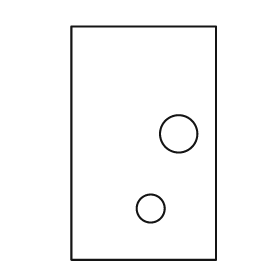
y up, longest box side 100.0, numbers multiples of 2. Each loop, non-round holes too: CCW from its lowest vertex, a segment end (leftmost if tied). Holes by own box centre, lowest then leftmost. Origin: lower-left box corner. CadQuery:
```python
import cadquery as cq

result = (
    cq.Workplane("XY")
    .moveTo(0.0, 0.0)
    .lineTo(62.0, 0.0)
    .lineTo(62.0, 100.0)
    .lineTo(0.0, 100.0)
    .close()
    .moveTo(34.0, 22.0)
    .circle(6.0)
    .moveTo(46.0, 54.0)
    .circle(8.0)
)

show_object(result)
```